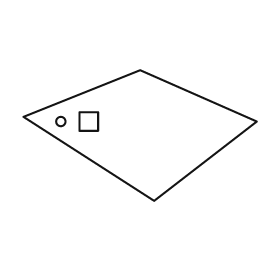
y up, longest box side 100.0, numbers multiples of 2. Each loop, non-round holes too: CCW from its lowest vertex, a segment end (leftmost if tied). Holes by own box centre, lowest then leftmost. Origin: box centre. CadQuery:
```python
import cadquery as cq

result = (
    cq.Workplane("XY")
    .moveTo(6.0, -28.0)
    .lineTo(50.0, 6.0)
    .lineTo(0.0, 28.0)
    .lineTo(-50.0, 8.0)
    .close()
    .moveTo(-34.0, 6.0)
    .circle(2.0)
    .moveTo(-26.0, 2.0)
    .lineTo(-18.0, 2.0)
    .lineTo(-18.0, 10.0)
    .lineTo(-26.0, 10.0)
    .close()
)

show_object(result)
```